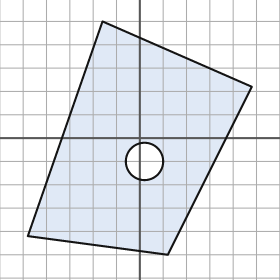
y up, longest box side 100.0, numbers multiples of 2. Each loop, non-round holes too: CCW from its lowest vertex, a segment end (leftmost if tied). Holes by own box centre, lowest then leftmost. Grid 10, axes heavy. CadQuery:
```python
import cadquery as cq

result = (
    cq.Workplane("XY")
    .moveTo(12.0, -50.0)
    .lineTo(48.0, 22.0)
    .lineTo(-16.0, 50.0)
    .lineTo(-48.0, -42.0)
    .close()
    .moveTo(2.0, -10.0)
    .circle(8.0)
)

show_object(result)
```